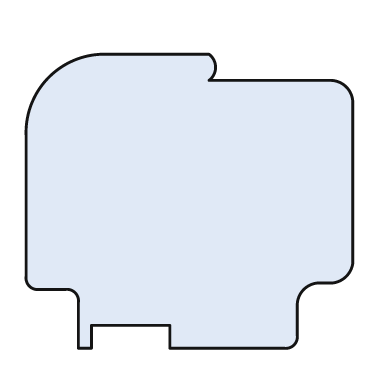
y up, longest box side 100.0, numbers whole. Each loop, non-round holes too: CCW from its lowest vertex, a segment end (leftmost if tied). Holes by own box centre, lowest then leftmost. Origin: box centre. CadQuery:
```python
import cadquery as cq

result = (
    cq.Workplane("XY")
    .moveTo(-34.0, -45.0)
    .lineTo(-30.0, -45.0)
    .lineTo(-30.0, -38.0)
    .lineTo(-6.0, -38.0)
    .lineTo(-6.0, -45.0)
    .lineTo(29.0, -45.0)
    .threePointArc((32.0, -44.0), (33.0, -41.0))
    .lineTo(33.0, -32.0)
    .threePointArc((35.0, -27.0), (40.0, -25.0))
    .lineTo(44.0, -25.0)
    .threePointArc((48.0, -23.0), (50.0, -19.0))
    .lineTo(50.0, 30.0)
    .threePointArc((48.0, 35.0), (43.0, 37.0))
    .lineTo(6.0, 37.0)
    .threePointArc((8.0, 41.0), (6.0, 45.0))
    .lineTo(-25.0, 45.0)
    .threePointArc((-43.0, 38.0), (-50.0, 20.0))
    .lineTo(-50.0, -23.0)
    .threePointArc((-49.0, -26.0), (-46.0, -27.0))
    .lineTo(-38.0, -27.0)
    .threePointArc((-35.0, -28.0), (-34.0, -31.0))
    .close()
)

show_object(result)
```